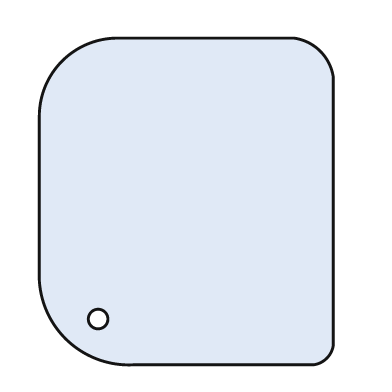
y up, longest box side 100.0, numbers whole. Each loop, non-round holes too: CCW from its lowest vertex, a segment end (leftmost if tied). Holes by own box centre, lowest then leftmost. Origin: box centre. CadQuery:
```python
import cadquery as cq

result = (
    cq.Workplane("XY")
    .moveTo(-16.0, -50.0)
    .lineTo(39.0, -50.0)
    .threePointArc((43.0, -48.0), (45.0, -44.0))
    .lineTo(45.0, 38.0)
    .threePointArc((41.0, 46.0), (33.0, 50.0))
    .lineTo(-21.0, 50.0)
    .threePointArc((-38.0, 43.0), (-45.0, 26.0))
    .lineTo(-45.0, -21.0)
    .threePointArc((-37.0, -42.0), (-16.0, -50.0))
    .close()
    .moveTo(-27.0, -36.0)
    .circle(3.0)
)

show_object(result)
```